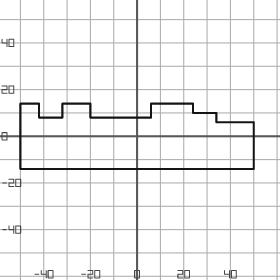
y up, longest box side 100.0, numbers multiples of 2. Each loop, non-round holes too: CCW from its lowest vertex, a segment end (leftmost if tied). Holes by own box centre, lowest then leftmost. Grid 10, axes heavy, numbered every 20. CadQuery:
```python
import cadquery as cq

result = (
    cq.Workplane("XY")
    .moveTo(-50.0, -14.0)
    .lineTo(50.0, -14.0)
    .lineTo(50.0, 6.0)
    .lineTo(34.0, 6.0)
    .lineTo(34.0, 10.0)
    .lineTo(24.0, 10.0)
    .lineTo(24.0, 14.0)
    .lineTo(6.0, 14.0)
    .lineTo(6.0, 8.0)
    .lineTo(-20.0, 8.0)
    .lineTo(-20.0, 14.0)
    .lineTo(-32.0, 14.0)
    .lineTo(-32.0, 8.0)
    .lineTo(-42.0, 8.0)
    .lineTo(-42.0, 14.0)
    .lineTo(-50.0, 14.0)
    .close()
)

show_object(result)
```